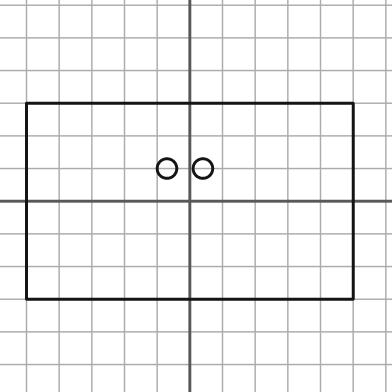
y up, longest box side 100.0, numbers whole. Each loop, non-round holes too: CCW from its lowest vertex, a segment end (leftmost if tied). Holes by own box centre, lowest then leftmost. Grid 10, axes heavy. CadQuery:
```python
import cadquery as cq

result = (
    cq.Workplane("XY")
    .moveTo(-50.0, -30.0)
    .lineTo(50.0, -30.0)
    .lineTo(50.0, 30.0)
    .lineTo(-50.0, 30.0)
    .close()
    .moveTo(-7.0, 10.0)
    .circle(3.0)
    .moveTo(4.0, 10.0)
    .circle(3.0)
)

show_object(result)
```